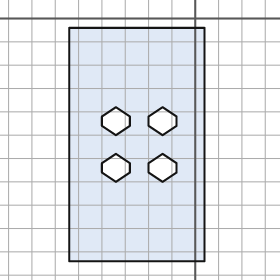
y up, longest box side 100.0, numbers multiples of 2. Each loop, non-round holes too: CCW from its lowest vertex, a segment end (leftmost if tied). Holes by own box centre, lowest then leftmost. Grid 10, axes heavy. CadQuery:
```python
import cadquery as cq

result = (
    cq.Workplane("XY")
    .moveTo(-54.0, -104.0)
    .lineTo(4.0, -104.0)
    .lineTo(4.0, -4.0)
    .lineTo(-54.0, -4.0)
    .close()
    .moveTo(-34.0, -70.0)
    .lineTo(-28.0, -66.0)
    .lineTo(-28.0, -62.0)
    .lineTo(-34.0, -58.0)
    .lineTo(-40.0, -62.0)
    .lineTo(-40.0, -66.0)
    .close()
    .moveTo(-14.0, -70.0)
    .lineTo(-8.0, -66.0)
    .lineTo(-8.0, -62.0)
    .lineTo(-14.0, -58.0)
    .lineTo(-20.0, -62.0)
    .lineTo(-20.0, -66.0)
    .close()
    .moveTo(-34.0, -50.0)
    .lineTo(-28.0, -46.0)
    .lineTo(-28.0, -42.0)
    .lineTo(-34.0, -38.0)
    .lineTo(-40.0, -42.0)
    .lineTo(-40.0, -46.0)
    .close()
    .moveTo(-14.0, -50.0)
    .lineTo(-8.0, -46.0)
    .lineTo(-8.0, -42.0)
    .lineTo(-14.0, -38.0)
    .lineTo(-20.0, -42.0)
    .lineTo(-20.0, -46.0)
    .close()
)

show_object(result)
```